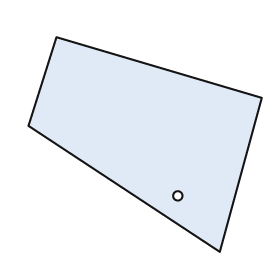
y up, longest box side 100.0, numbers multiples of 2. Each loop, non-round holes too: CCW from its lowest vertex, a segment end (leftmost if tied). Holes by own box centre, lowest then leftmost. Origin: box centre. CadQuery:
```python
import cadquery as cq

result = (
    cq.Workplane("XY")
    .moveTo(32.0, -46.0)
    .lineTo(50.0, 20.0)
    .lineTo(-38.0, 46.0)
    .lineTo(-50.0, 8.0)
    .close()
    .moveTo(14.0, -22.0)
    .circle(2.0)
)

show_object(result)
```